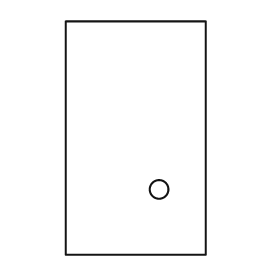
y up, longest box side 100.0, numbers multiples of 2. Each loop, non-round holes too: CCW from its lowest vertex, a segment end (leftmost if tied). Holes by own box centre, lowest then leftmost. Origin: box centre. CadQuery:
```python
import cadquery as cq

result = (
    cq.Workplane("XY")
    .moveTo(-30.0, -50.0)
    .lineTo(30.0, -50.0)
    .lineTo(30.0, 50.0)
    .lineTo(-30.0, 50.0)
    .close()
    .moveTo(10.0, -22.0)
    .circle(4.0)
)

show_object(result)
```